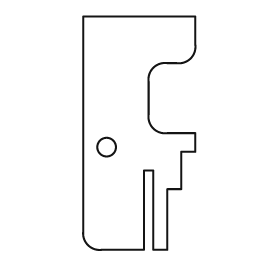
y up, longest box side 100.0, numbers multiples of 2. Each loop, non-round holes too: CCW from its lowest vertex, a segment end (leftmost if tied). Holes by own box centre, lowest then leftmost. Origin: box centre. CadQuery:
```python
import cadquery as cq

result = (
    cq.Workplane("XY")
    .moveTo(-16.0, -50.0)
    .lineTo(2.0, -50.0)
    .lineTo(2.0, -16.0)
    .lineTo(6.0, -16.0)
    .lineTo(6.0, -50.0)
    .lineTo(12.0, -50.0)
    .lineTo(12.0, -24.0)
    .lineTo(18.0, -24.0)
    .lineTo(18.0, -8.0)
    .lineTo(24.0, -8.0)
    .lineTo(24.0, 0.0)
    .lineTo(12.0, 0.0)
    .threePointArc((6.0, 2.0), (4.0, 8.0))
    .lineTo(4.0, 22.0)
    .threePointArc((6.0, 28.0), (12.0, 30.0))
    .lineTo(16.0, 30.0)
    .threePointArc((22.0, 32.0), (24.0, 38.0))
    .lineTo(24.0, 50.0)
    .lineTo(-24.0, 50.0)
    .lineTo(-24.0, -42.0)
    .threePointArc((-22.0, -48.0), (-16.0, -50.0))
    .close()
    .moveTo(-14.0, -6.0)
    .circle(4.0)
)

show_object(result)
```